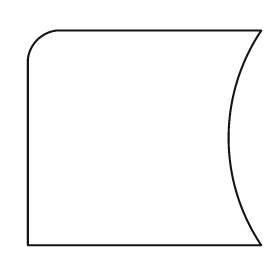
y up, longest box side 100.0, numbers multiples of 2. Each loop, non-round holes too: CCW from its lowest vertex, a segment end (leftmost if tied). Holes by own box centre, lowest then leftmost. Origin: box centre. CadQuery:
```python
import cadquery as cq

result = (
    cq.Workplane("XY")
    .moveTo(-50.0, -46.0)
    .lineTo(50.0, -46.0)
    .threePointArc((36.0, 0.0), (50.0, 46.0))
    .lineTo(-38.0, 46.0)
    .threePointArc((-46.0, 42.0), (-50.0, 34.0))
    .close()
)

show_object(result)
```